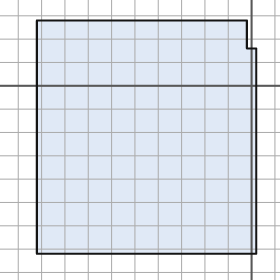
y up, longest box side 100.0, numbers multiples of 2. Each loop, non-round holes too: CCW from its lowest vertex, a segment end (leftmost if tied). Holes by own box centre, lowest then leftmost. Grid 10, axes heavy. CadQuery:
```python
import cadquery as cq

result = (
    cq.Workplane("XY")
    .moveTo(-92.0, -72.0)
    .lineTo(2.0, -72.0)
    .lineTo(2.0, 16.0)
    .lineTo(-2.0, 16.0)
    .lineTo(-2.0, 28.0)
    .lineTo(-92.0, 28.0)
    .close()
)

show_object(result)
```